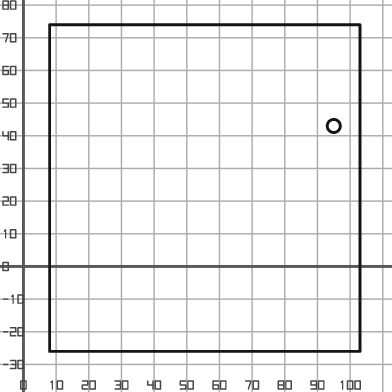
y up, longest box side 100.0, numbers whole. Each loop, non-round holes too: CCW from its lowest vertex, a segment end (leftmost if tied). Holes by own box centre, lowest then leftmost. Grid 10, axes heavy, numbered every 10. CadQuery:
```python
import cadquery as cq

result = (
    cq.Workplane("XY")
    .moveTo(8.0, -26.0)
    .lineTo(103.0, -26.0)
    .lineTo(103.0, 74.0)
    .lineTo(8.0, 74.0)
    .close()
    .moveTo(95.0, 43.0)
    .circle(2.0)
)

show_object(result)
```